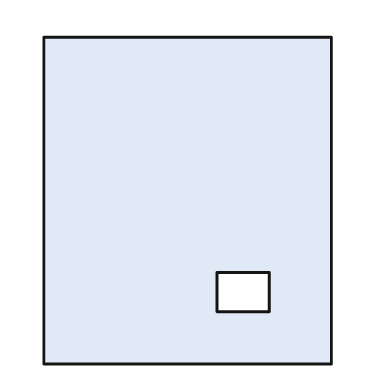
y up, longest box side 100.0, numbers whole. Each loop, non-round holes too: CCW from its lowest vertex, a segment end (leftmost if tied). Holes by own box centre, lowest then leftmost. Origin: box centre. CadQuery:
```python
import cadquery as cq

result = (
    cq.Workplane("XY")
    .moveTo(-44.0, -50.0)
    .lineTo(44.0, -50.0)
    .lineTo(44.0, 50.0)
    .lineTo(-44.0, 50.0)
    .close()
    .moveTo(9.0, -34.0)
    .lineTo(25.0, -34.0)
    .lineTo(25.0, -22.0)
    .lineTo(9.0, -22.0)
    .close()
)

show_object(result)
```